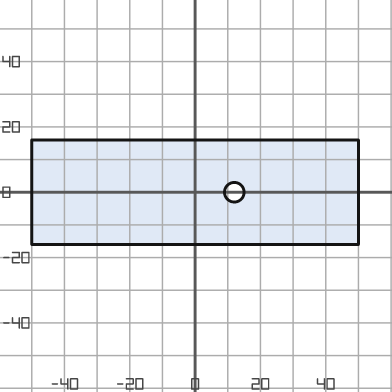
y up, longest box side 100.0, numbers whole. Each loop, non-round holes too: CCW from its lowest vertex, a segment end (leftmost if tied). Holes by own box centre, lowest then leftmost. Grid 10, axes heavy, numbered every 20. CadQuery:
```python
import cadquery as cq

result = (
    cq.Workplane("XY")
    .moveTo(-50.0, -16.0)
    .lineTo(50.0, -16.0)
    .lineTo(50.0, 16.0)
    .lineTo(-50.0, 16.0)
    .close()
    .moveTo(12.0, 0.0)
    .circle(3.0)
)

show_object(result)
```